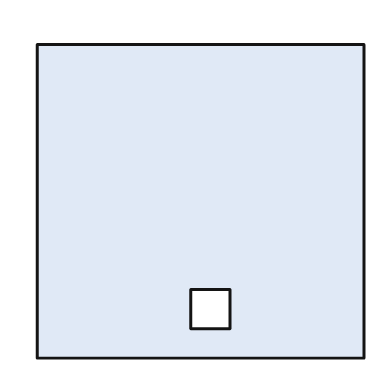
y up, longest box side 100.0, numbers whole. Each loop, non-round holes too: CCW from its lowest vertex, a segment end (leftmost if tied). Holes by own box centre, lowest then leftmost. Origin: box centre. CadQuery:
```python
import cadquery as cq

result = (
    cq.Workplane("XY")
    .moveTo(-50.0, -48.0)
    .lineTo(50.0, -48.0)
    .lineTo(50.0, 48.0)
    .lineTo(-50.0, 48.0)
    .close()
    .moveTo(-3.0, -39.0)
    .lineTo(9.0, -39.0)
    .lineTo(9.0, -27.0)
    .lineTo(-3.0, -27.0)
    .close()
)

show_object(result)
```